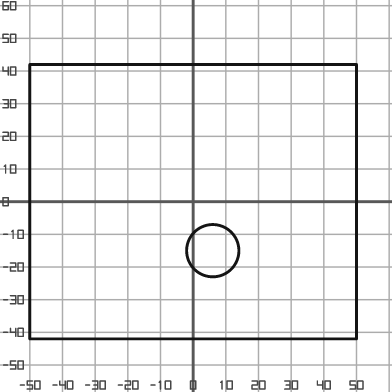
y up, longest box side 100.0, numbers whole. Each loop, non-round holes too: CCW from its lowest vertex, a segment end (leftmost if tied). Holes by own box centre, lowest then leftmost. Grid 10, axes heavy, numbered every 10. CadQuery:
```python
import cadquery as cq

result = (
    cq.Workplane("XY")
    .moveTo(-50.0, -42.0)
    .lineTo(50.0, -42.0)
    .lineTo(50.0, 42.0)
    .lineTo(-50.0, 42.0)
    .close()
    .moveTo(6.0, -15.0)
    .circle(8.0)
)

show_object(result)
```